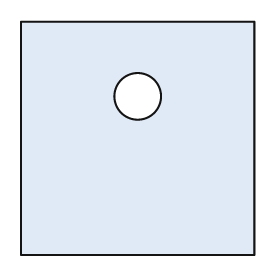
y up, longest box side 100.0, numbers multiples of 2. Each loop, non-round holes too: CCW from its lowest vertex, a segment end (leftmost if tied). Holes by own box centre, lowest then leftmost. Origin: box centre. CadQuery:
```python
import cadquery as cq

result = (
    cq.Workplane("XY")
    .moveTo(-50.0, -50.0)
    .lineTo(50.0, -50.0)
    .lineTo(50.0, 50.0)
    .lineTo(-50.0, 50.0)
    .close()
    .moveTo(0.0, 18.0)
    .circle(10.0)
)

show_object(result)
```